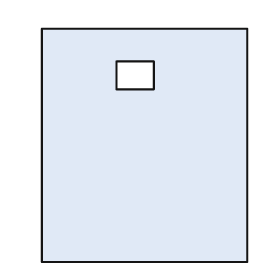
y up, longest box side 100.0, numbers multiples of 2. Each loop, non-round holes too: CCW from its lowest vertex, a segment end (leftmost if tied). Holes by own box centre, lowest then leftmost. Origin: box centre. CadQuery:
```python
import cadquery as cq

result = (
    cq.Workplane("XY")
    .moveTo(-44.0, -50.0)
    .lineTo(44.0, -50.0)
    .lineTo(44.0, 50.0)
    .lineTo(-44.0, 50.0)
    .close()
    .moveTo(-12.0, 24.0)
    .lineTo(4.0, 24.0)
    .lineTo(4.0, 36.0)
    .lineTo(-12.0, 36.0)
    .close()
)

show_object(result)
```